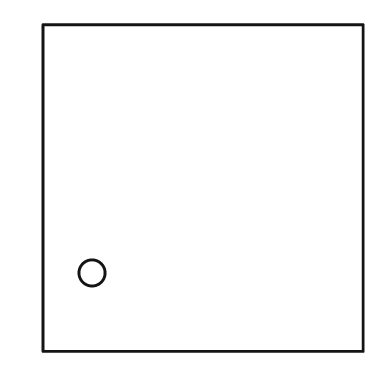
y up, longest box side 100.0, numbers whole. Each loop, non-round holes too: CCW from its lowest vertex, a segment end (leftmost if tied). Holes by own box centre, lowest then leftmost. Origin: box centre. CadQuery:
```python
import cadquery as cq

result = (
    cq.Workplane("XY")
    .moveTo(-49.0, -50.0)
    .lineTo(49.0, -50.0)
    .lineTo(49.0, 50.0)
    .lineTo(-49.0, 50.0)
    .close()
    .moveTo(-34.0, -26.0)
    .circle(4.0)
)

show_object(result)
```